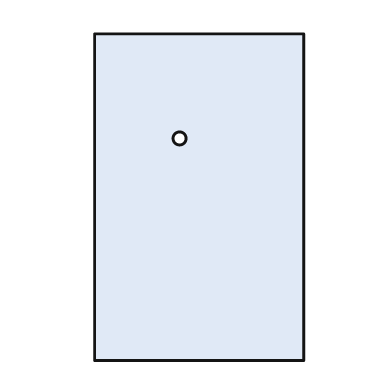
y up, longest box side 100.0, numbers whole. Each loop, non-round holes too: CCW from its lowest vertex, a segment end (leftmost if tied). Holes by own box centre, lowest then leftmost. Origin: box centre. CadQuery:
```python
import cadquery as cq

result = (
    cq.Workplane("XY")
    .moveTo(-32.0, -50.0)
    .lineTo(32.0, -50.0)
    .lineTo(32.0, 50.0)
    .lineTo(-32.0, 50.0)
    .close()
    .moveTo(-6.0, 18.0)
    .circle(2.0)
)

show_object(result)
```